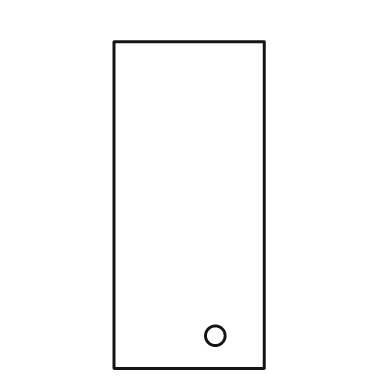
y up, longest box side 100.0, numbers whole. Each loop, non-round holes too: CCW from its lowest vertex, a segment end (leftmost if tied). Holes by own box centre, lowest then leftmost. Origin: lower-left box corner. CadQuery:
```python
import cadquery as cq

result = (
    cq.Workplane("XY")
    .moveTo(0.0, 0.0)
    .lineTo(46.0, 0.0)
    .lineTo(46.0, 100.0)
    .lineTo(0.0, 100.0)
    .close()
    .moveTo(31.0, 10.0)
    .circle(3.0)
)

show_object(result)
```